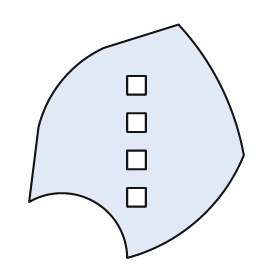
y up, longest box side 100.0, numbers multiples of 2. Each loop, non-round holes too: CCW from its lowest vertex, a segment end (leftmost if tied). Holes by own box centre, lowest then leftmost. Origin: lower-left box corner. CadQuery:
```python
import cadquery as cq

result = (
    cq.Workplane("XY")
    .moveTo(42.0, 0.0)
    .threePointArc((72.0, 16.0), (92.0, 44.0))
    .threePointArc((82.0, 74.0), (64.0, 100.0))
    .lineTo(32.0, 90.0)
    .threePointArc((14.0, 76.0), (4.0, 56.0))
    .lineTo(0.0, 24.0)
    .threePointArc((28.0, 24.0), (42.0, 0.0))
    .close()
    .moveTo(42.0, 22.0)
    .lineTo(50.0, 22.0)
    .lineTo(50.0, 30.0)
    .lineTo(42.0, 30.0)
    .close()
    .moveTo(42.0, 38.0)
    .lineTo(50.0, 38.0)
    .lineTo(50.0, 46.0)
    .lineTo(42.0, 46.0)
    .close()
    .moveTo(42.0, 54.0)
    .lineTo(50.0, 54.0)
    .lineTo(50.0, 62.0)
    .lineTo(42.0, 62.0)
    .close()
    .moveTo(42.0, 70.0)
    .lineTo(50.0, 70.0)
    .lineTo(50.0, 78.0)
    .lineTo(42.0, 78.0)
    .close()
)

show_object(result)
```